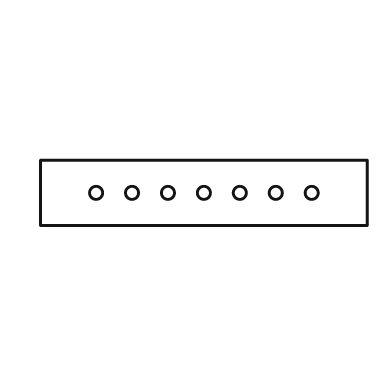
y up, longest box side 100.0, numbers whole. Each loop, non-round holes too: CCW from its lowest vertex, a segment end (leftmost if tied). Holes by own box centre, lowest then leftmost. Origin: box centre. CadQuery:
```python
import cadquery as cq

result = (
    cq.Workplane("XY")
    .moveTo(-50.0, -10.0)
    .lineTo(50.0, -10.0)
    .lineTo(50.0, 10.0)
    .lineTo(-50.0, 10.0)
    .close()
    .moveTo(-33.0, 0.0)
    .circle(2.0)
    .moveTo(-22.0, 0.0)
    .circle(2.0)
    .moveTo(-11.0, 0.0)
    .circle(2.0)
    .moveTo(0.0, 0.0)
    .circle(2.0)
    .moveTo(11.0, 0.0)
    .circle(2.0)
    .moveTo(22.0, 0.0)
    .circle(2.0)
    .moveTo(33.0, 0.0)
    .circle(2.0)
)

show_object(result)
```